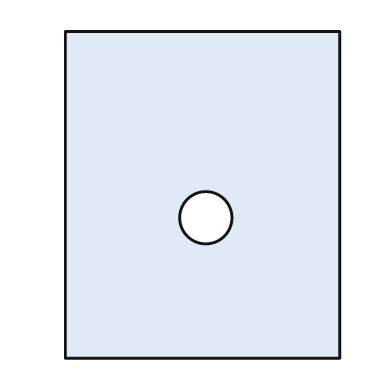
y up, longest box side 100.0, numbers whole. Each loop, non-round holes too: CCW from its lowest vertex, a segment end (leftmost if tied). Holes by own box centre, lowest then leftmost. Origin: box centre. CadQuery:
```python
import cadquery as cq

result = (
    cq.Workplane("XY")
    .moveTo(-42.0, -50.0)
    .lineTo(42.0, -50.0)
    .lineTo(42.0, 50.0)
    .lineTo(-42.0, 50.0)
    .close()
    .moveTo(1.0, -7.0)
    .circle(8.0)
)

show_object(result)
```